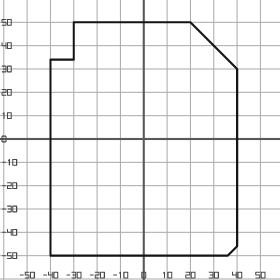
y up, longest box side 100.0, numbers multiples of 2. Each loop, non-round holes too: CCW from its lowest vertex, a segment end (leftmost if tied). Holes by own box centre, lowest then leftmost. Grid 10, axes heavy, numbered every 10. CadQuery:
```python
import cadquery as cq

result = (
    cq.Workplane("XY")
    .moveTo(-40.0, -50.0)
    .lineTo(36.0, -50.0)
    .lineTo(40.0, -46.0)
    .lineTo(40.0, 30.0)
    .lineTo(20.0, 50.0)
    .lineTo(-30.0, 50.0)
    .lineTo(-30.0, 34.0)
    .lineTo(-40.0, 34.0)
    .close()
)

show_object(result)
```